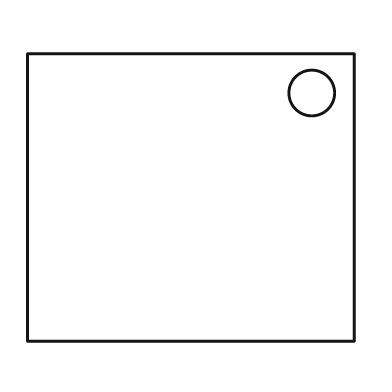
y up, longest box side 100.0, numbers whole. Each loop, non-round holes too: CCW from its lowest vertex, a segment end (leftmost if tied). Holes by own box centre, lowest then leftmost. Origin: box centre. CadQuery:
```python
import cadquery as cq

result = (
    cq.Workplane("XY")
    .moveTo(-50.0, -44.0)
    .lineTo(50.0, -44.0)
    .lineTo(50.0, 44.0)
    .lineTo(-50.0, 44.0)
    .close()
    .moveTo(37.0, 32.0)
    .circle(7.0)
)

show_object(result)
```